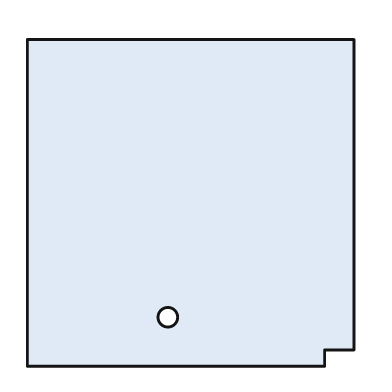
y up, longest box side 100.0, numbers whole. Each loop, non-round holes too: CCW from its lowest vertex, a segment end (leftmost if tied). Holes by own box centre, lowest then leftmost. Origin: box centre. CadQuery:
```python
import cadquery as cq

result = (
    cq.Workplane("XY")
    .moveTo(-50.0, -50.0)
    .lineTo(41.0, -50.0)
    .lineTo(41.0, -45.0)
    .lineTo(50.0, -45.0)
    .lineTo(50.0, 50.0)
    .lineTo(-50.0, 50.0)
    .close()
    .moveTo(-7.0, -35.0)
    .circle(3.0)
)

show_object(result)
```